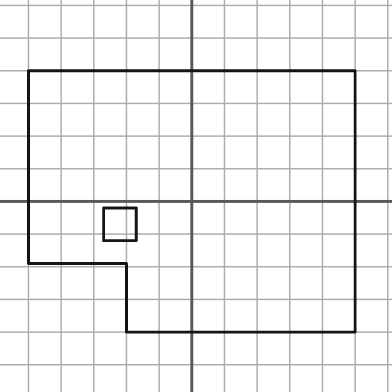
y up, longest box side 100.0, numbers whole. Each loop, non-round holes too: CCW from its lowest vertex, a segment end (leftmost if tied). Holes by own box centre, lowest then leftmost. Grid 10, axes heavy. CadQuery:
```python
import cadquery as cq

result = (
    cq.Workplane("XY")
    .moveTo(-20.0, -40.0)
    .lineTo(50.0, -40.0)
    .lineTo(50.0, 40.0)
    .lineTo(-50.0, 40.0)
    .lineTo(-50.0, -19.0)
    .lineTo(-20.0, -19.0)
    .close()
    .moveTo(-27.0, -12.0)
    .lineTo(-17.0, -12.0)
    .lineTo(-17.0, -2.0)
    .lineTo(-27.0, -2.0)
    .close()
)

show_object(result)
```